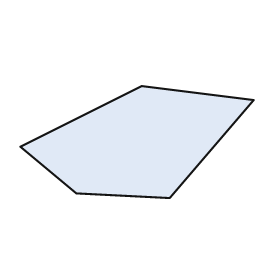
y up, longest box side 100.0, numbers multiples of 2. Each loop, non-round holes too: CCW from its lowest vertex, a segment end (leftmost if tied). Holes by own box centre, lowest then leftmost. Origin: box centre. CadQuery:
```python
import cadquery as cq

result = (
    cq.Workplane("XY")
    .moveTo(14.0, -24.0)
    .lineTo(50.0, 18.0)
    .lineTo(2.0, 24.0)
    .lineTo(-50.0, -2.0)
    .lineTo(-26.0, -22.0)
    .close()
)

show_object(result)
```